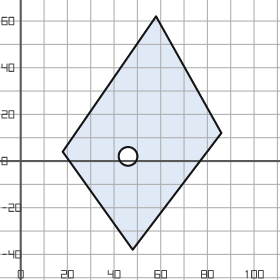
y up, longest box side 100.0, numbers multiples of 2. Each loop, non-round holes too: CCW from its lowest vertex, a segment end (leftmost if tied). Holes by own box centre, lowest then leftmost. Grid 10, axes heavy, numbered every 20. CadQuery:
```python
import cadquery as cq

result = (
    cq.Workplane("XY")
    .moveTo(48.0, -38.0)
    .lineTo(86.0, 12.0)
    .lineTo(58.0, 62.0)
    .lineTo(18.0, 4.0)
    .close()
    .moveTo(46.0, 2.0)
    .circle(4.0)
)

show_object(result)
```